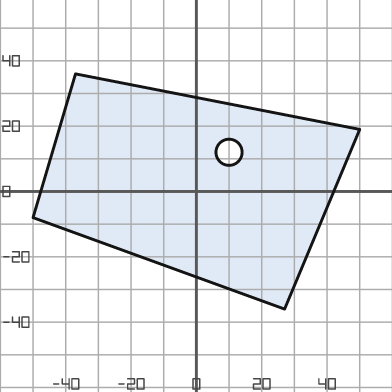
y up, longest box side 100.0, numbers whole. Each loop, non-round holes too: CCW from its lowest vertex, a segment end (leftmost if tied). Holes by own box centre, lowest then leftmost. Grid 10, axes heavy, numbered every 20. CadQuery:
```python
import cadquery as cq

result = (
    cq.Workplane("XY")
    .moveTo(27.0, -36.0)
    .lineTo(50.0, 19.0)
    .lineTo(-37.0, 36.0)
    .lineTo(-50.0, -8.0)
    .close()
    .moveTo(10.0, 12.0)
    .circle(4.0)
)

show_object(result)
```